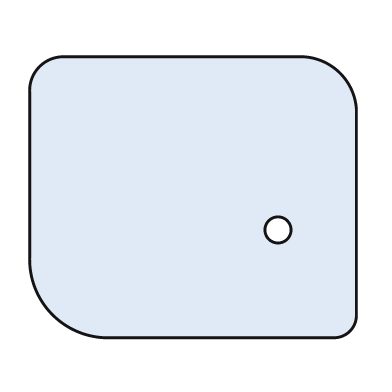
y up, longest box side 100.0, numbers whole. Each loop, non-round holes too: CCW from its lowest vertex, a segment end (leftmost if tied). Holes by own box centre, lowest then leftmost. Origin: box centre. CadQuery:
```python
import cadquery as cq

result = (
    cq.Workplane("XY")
    .moveTo(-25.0, -43.0)
    .lineTo(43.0, -43.0)
    .threePointArc((48.0, -41.0), (50.0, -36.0))
    .lineTo(50.0, 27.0)
    .threePointArc((45.0, 38.0), (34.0, 43.0))
    .lineTo(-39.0, 43.0)
    .threePointArc((-47.0, 40.0), (-50.0, 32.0))
    .lineTo(-50.0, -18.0)
    .threePointArc((-43.0, -36.0), (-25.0, -43.0))
    .close()
    .moveTo(26.0, -10.0)
    .circle(4.0)
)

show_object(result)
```